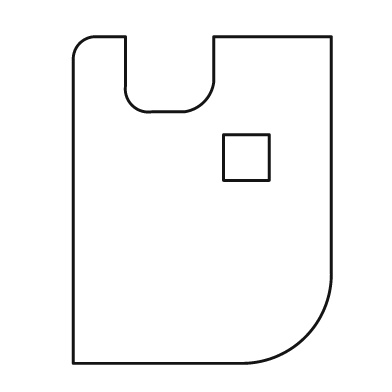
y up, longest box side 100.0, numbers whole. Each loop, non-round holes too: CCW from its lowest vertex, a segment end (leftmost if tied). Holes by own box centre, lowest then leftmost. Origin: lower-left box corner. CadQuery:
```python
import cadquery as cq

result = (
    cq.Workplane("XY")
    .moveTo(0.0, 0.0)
    .lineTo(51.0, 0.0)
    .threePointArc((71.0, 8.0), (79.0, 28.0))
    .lineTo(79.0, 100.0)
    .lineTo(43.0, 100.0)
    .lineTo(43.0, 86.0)
    .threePointArc((40.0, 80.0), (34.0, 77.0))
    .lineTo(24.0, 77.0)
    .threePointArc((18.0, 79.0), (16.0, 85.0))
    .lineTo(16.0, 100.0)
    .lineTo(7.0, 100.0)
    .threePointArc((2.0, 98.0), (0.0, 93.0))
    .close()
    .moveTo(46.0, 56.0)
    .lineTo(60.0, 56.0)
    .lineTo(60.0, 70.0)
    .lineTo(46.0, 70.0)
    .close()
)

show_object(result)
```